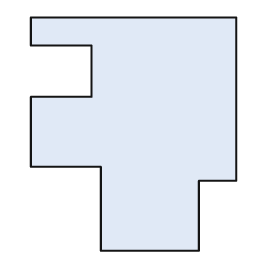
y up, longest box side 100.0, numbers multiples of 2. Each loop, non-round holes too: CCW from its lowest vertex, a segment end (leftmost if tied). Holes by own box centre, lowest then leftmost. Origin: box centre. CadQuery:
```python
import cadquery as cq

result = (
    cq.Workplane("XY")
    .moveTo(-14.0, -50.0)
    .lineTo(28.0, -50.0)
    .lineTo(28.0, -20.0)
    .lineTo(44.0, -20.0)
    .lineTo(44.0, 50.0)
    .lineTo(-44.0, 50.0)
    .lineTo(-44.0, 38.0)
    .lineTo(-18.0, 38.0)
    .lineTo(-18.0, 16.0)
    .lineTo(-44.0, 16.0)
    .lineTo(-44.0, -14.0)
    .lineTo(-14.0, -14.0)
    .close()
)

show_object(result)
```